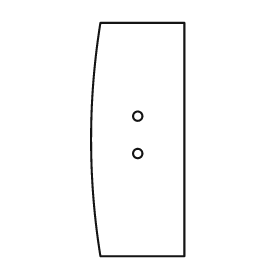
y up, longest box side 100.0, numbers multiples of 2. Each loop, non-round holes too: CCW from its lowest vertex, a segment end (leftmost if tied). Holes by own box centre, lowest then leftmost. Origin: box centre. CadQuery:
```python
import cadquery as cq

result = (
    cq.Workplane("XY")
    .moveTo(-16.0, -50.0)
    .lineTo(20.0, -50.0)
    .lineTo(20.0, 50.0)
    .lineTo(-16.0, 50.0)
    .threePointArc((-20.0, 0.0), (-16.0, -50.0))
    .close()
    .moveTo(0.0, -6.0)
    .circle(2.0)
    .moveTo(0.0, 10.0)
    .circle(2.0)
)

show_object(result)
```